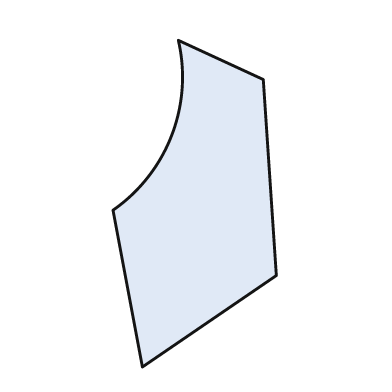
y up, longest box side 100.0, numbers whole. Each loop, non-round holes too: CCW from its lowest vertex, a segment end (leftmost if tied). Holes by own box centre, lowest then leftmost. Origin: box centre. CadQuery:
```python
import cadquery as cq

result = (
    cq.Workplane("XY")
    .moveTo(-16.0, -50.0)
    .lineTo(25.0, -22.0)
    .lineTo(21.0, 38.0)
    .lineTo(-5.0, 50.0)
    .threePointArc((-7.0, 21.0), (-25.0, -2.0))
    .close()
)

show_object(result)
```